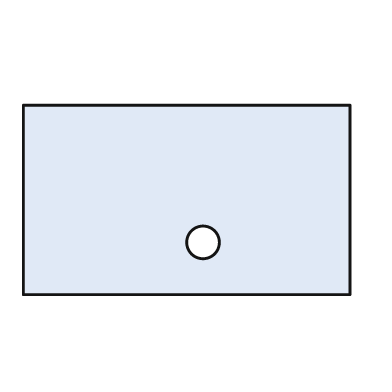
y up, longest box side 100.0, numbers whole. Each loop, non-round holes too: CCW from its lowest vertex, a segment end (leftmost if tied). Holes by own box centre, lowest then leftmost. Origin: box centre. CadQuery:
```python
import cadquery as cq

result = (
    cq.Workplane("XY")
    .moveTo(-50.0, -29.0)
    .lineTo(50.0, -29.0)
    .lineTo(50.0, 29.0)
    .lineTo(-50.0, 29.0)
    .close()
    .moveTo(5.0, -13.0)
    .circle(5.0)
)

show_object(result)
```